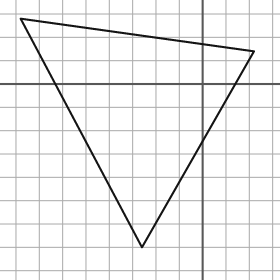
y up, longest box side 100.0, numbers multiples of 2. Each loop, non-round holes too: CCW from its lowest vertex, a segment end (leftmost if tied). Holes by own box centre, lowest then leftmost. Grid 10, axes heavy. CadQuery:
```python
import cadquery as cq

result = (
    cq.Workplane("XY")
    .moveTo(-26.0, -70.0)
    .lineTo(22.0, 14.0)
    .lineTo(-78.0, 28.0)
    .close()
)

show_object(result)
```